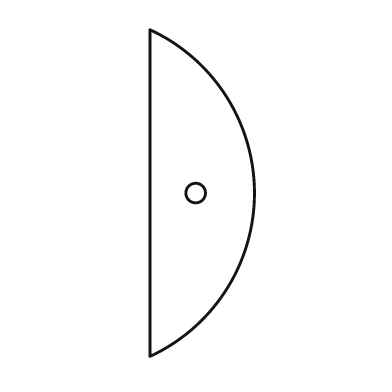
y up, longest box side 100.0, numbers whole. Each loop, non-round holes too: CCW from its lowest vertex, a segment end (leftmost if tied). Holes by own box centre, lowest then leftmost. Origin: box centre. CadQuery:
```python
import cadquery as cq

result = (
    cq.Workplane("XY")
    .moveTo(-16.0, -50.0)
    .threePointArc((16.0, 0.0), (-16.0, 50.0))
    .close()
    .moveTo(-2.0, 0.0)
    .circle(3.0)
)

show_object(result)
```